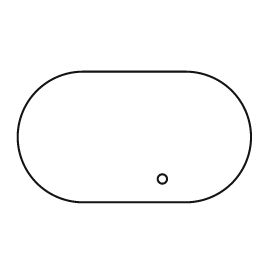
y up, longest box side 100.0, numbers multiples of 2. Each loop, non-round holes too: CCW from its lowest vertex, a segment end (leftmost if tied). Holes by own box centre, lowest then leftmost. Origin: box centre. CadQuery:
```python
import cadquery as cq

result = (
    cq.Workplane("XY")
    .moveTo(-22.0, -28.0)
    .lineTo(22.0, -28.0)
    .threePointArc((50.0, 0.0), (22.0, 28.0))
    .lineTo(-22.0, 28.0)
    .threePointArc((-50.0, 0.0), (-22.0, -28.0))
    .close()
    .moveTo(12.0, -18.0)
    .circle(2.0)
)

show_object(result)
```